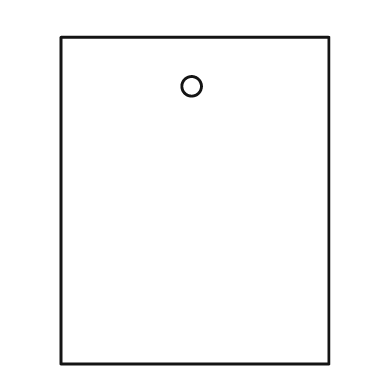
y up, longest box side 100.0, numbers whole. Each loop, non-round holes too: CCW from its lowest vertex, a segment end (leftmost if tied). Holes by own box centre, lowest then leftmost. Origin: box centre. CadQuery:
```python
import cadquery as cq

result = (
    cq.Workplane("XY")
    .moveTo(-41.0, -50.0)
    .lineTo(41.0, -50.0)
    .lineTo(41.0, 50.0)
    .lineTo(-41.0, 50.0)
    .close()
    .moveTo(-1.0, 35.0)
    .circle(3.0)
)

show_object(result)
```